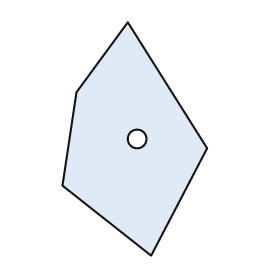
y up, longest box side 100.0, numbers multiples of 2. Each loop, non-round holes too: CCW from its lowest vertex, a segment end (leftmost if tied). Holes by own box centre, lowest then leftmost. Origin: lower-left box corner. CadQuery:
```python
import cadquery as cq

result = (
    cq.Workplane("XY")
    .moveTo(38.0, 0.0)
    .lineTo(62.0, 46.0)
    .lineTo(28.0, 100.0)
    .lineTo(6.0, 70.0)
    .lineTo(0.0, 30.0)
    .close()
    .moveTo(32.0, 50.0)
    .circle(4.0)
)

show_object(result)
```